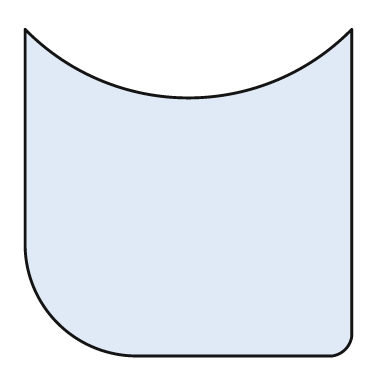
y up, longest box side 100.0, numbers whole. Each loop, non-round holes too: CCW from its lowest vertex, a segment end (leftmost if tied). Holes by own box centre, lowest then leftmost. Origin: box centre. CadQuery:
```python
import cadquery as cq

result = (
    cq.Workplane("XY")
    .moveTo(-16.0, -50.0)
    .lineTo(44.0, -50.0)
    .threePointArc((48.0, -48.0), (50.0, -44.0))
    .lineTo(50.0, 50.0)
    .threePointArc((0.0, 29.0), (-50.0, 50.0))
    .lineTo(-50.0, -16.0)
    .threePointArc((-40.0, -40.0), (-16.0, -50.0))
    .close()
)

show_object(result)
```